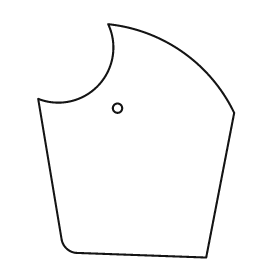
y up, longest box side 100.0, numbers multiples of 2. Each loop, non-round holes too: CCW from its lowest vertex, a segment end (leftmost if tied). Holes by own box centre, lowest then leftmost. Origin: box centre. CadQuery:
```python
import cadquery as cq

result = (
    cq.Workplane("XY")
    .moveTo(30.0, -50.0)
    .lineTo(42.0, 12.0)
    .threePointArc((20.0, 38.0), (-12.0, 50.0))
    .threePointArc((-16.0, 24.0), (-42.0, 18.0))
    .lineTo(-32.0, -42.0)
    .threePointArc((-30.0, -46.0), (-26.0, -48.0))
    .close()
    .moveTo(-8.0, 14.0)
    .circle(2.0)
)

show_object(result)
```